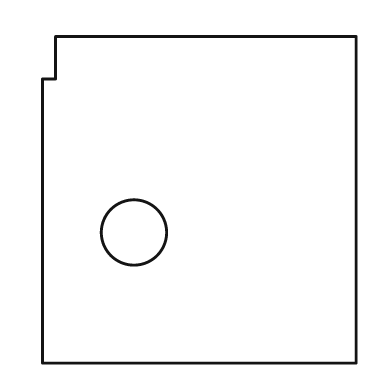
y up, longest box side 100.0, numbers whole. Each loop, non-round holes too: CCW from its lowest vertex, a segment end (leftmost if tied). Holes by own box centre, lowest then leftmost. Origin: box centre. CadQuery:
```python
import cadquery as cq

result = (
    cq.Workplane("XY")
    .moveTo(-48.0, -50.0)
    .lineTo(48.0, -50.0)
    .lineTo(48.0, 50.0)
    .lineTo(-44.0, 50.0)
    .lineTo(-44.0, 37.0)
    .lineTo(-48.0, 37.0)
    .close()
    .moveTo(-20.0, -10.0)
    .circle(10.0)
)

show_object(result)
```